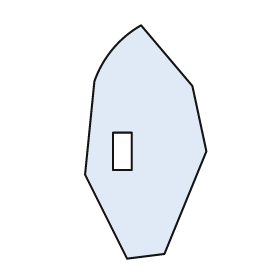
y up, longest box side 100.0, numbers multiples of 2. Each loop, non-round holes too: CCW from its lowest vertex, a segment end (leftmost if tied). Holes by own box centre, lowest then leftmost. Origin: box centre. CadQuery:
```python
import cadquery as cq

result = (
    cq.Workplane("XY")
    .moveTo(-8.0, -50.0)
    .lineTo(8.0, -48.0)
    .lineTo(26.0, -4.0)
    .lineTo(20.0, 24.0)
    .lineTo(-2.0, 50.0)
    .threePointArc((-14.0, 40.0), (-22.0, 26.0))
    .lineTo(-26.0, -14.0)
    .close()
    .moveTo(-14.0, -12.0)
    .lineTo(-6.0, -12.0)
    .lineTo(-6.0, 4.0)
    .lineTo(-14.0, 4.0)
    .close()
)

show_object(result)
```